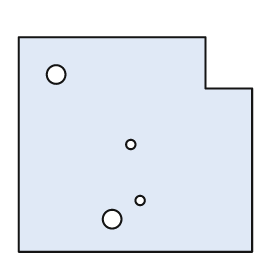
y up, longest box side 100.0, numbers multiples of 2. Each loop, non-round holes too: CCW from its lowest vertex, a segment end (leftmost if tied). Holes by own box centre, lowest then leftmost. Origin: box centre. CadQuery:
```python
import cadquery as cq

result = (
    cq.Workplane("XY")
    .moveTo(-50.0, -46.0)
    .lineTo(50.0, -46.0)
    .lineTo(50.0, 24.0)
    .lineTo(30.0, 24.0)
    .lineTo(30.0, 46.0)
    .lineTo(-50.0, 46.0)
    .close()
    .moveTo(-10.0, -32.0)
    .circle(4.0)
    .moveTo(2.0, -24.0)
    .circle(2.0)
    .moveTo(-2.0, 0.0)
    .circle(2.0)
    .moveTo(-34.0, 30.0)
    .circle(4.0)
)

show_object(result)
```